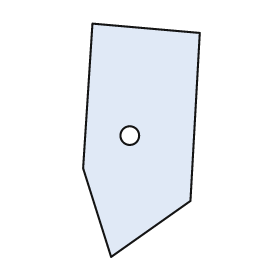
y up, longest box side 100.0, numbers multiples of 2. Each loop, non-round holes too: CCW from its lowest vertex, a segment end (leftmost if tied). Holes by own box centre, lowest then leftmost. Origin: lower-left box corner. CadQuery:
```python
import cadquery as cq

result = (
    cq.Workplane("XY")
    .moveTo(12.0, 0.0)
    .lineTo(46.0, 24.0)
    .lineTo(50.0, 96.0)
    .lineTo(4.0, 100.0)
    .lineTo(0.0, 38.0)
    .close()
    .moveTo(20.0, 52.0)
    .circle(4.0)
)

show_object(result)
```